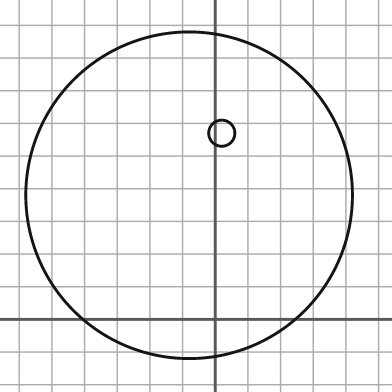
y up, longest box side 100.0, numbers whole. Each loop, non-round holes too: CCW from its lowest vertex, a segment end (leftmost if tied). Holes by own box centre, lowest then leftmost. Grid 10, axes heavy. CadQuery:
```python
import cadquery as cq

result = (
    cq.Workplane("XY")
    .moveTo(-8.0, 38.0)
    .circle(50.0)
    .moveTo(2.0, 57.0)
    .circle(4.0)
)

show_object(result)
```